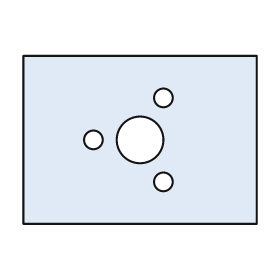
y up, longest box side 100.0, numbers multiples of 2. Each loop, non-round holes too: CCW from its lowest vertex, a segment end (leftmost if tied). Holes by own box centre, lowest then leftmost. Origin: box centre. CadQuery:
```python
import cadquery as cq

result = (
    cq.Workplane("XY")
    .moveTo(-50.0, -36.0)
    .lineTo(50.0, -36.0)
    .lineTo(50.0, 36.0)
    .lineTo(-50.0, 36.0)
    .close()
    .moveTo(10.0, -18.0)
    .circle(4.0)
    .moveTo(-20.0, 0.0)
    .circle(4.0)
    .moveTo(0.0, 0.0)
    .circle(10.0)
    .moveTo(10.0, 18.0)
    .circle(4.0)
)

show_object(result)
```